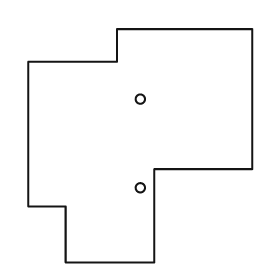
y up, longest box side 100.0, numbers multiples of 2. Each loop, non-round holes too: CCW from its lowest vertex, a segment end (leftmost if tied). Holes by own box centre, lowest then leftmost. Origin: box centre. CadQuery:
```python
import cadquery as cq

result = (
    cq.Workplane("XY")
    .moveTo(-32.0, -50.0)
    .lineTo(6.0, -50.0)
    .lineTo(6.0, -10.0)
    .lineTo(48.0, -10.0)
    .lineTo(48.0, 50.0)
    .lineTo(-10.0, 50.0)
    .lineTo(-10.0, 36.0)
    .lineTo(-48.0, 36.0)
    .lineTo(-48.0, -26.0)
    .lineTo(-32.0, -26.0)
    .close()
    .moveTo(0.0, -18.0)
    .circle(2.0)
    .moveTo(0.0, 20.0)
    .circle(2.0)
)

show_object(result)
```